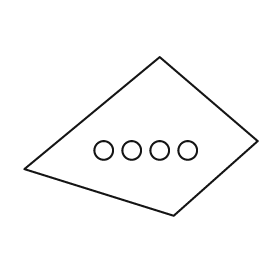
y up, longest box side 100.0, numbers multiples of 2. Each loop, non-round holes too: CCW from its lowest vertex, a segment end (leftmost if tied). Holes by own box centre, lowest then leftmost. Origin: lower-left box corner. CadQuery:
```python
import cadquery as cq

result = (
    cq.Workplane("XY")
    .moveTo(64.0, 0.0)
    .lineTo(100.0, 32.0)
    .lineTo(58.0, 68.0)
    .lineTo(0.0, 20.0)
    .close()
    .moveTo(34.0, 28.0)
    .circle(4.0)
    .moveTo(46.0, 28.0)
    .circle(4.0)
    .moveTo(58.0, 28.0)
    .circle(4.0)
    .moveTo(70.0, 28.0)
    .circle(4.0)
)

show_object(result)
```